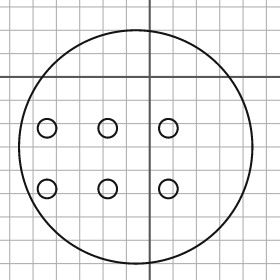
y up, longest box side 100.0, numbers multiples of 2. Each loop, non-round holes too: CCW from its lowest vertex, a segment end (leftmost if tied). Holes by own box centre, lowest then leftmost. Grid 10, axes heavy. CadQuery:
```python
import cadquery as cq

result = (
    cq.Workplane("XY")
    .moveTo(-6.0, -30.0)
    .circle(50.0)
    .moveTo(-44.0, -48.0)
    .circle(4.0)
    .moveTo(-18.0, -48.0)
    .circle(4.0)
    .moveTo(8.0, -48.0)
    .circle(4.0)
    .moveTo(-44.0, -22.0)
    .circle(4.0)
    .moveTo(-18.0, -22.0)
    .circle(4.0)
    .moveTo(8.0, -22.0)
    .circle(4.0)
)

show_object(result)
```